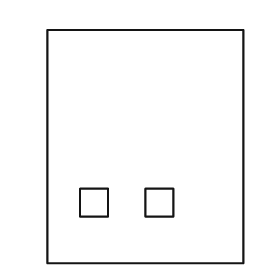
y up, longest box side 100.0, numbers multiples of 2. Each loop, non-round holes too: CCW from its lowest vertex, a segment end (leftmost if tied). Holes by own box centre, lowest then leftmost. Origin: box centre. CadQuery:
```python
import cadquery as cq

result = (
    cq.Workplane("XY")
    .moveTo(-42.0, -50.0)
    .lineTo(42.0, -50.0)
    .lineTo(42.0, 50.0)
    .lineTo(-42.0, 50.0)
    .close()
    .moveTo(-28.0, -30.0)
    .lineTo(-16.0, -30.0)
    .lineTo(-16.0, -18.0)
    .lineTo(-28.0, -18.0)
    .close()
    .moveTo(0.0, -30.0)
    .lineTo(12.0, -30.0)
    .lineTo(12.0, -18.0)
    .lineTo(0.0, -18.0)
    .close()
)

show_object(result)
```